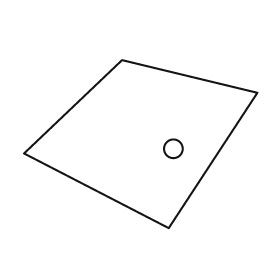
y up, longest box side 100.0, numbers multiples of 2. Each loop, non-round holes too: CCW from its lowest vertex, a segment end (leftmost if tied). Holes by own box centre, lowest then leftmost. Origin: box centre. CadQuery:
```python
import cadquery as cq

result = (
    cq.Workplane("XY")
    .moveTo(12.0, -36.0)
    .lineTo(50.0, 22.0)
    .lineTo(-8.0, 36.0)
    .lineTo(-50.0, -4.0)
    .close()
    .moveTo(14.0, -2.0)
    .circle(4.0)
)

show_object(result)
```